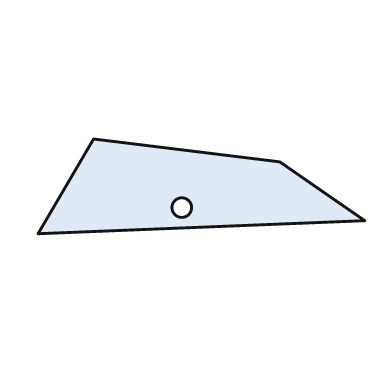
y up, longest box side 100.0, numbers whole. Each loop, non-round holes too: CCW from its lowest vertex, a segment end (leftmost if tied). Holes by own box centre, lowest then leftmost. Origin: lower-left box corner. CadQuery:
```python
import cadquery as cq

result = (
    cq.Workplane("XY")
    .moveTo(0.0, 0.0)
    .lineTo(100.0, 4.0)
    .lineTo(74.0, 22.0)
    .lineTo(17.0, 29.0)
    .close()
    .moveTo(44.0, 8.0)
    .circle(3.0)
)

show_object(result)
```